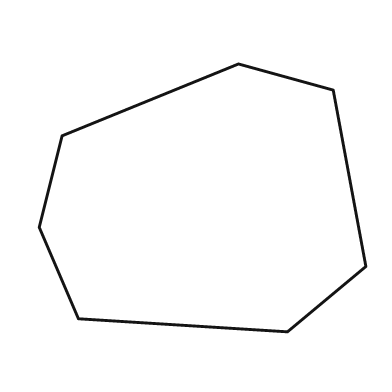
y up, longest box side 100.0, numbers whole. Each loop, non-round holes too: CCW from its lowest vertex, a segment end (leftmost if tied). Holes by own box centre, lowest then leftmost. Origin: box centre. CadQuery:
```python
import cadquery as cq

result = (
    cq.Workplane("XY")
    .moveTo(26.0, -41.0)
    .lineTo(50.0, -21.0)
    .lineTo(40.0, 33.0)
    .lineTo(11.0, 41.0)
    .lineTo(-43.0, 19.0)
    .lineTo(-50.0, -9.0)
    .lineTo(-38.0, -37.0)
    .close()
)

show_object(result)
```